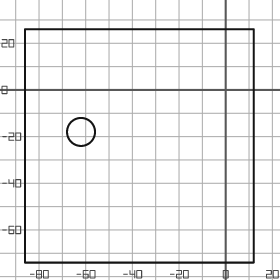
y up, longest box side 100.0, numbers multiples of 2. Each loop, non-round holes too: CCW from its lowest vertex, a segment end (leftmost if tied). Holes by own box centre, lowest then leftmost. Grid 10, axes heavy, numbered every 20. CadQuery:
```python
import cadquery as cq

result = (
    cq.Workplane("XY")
    .moveTo(-86.0, -74.0)
    .lineTo(12.0, -74.0)
    .lineTo(12.0, 26.0)
    .lineTo(-86.0, 26.0)
    .close()
    .moveTo(-62.0, -18.0)
    .circle(6.0)
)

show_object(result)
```